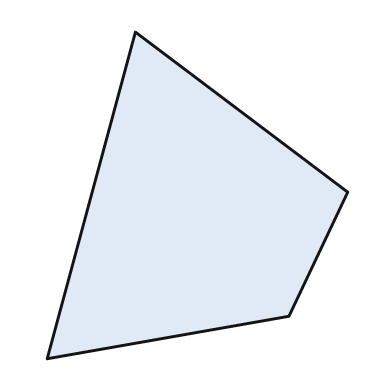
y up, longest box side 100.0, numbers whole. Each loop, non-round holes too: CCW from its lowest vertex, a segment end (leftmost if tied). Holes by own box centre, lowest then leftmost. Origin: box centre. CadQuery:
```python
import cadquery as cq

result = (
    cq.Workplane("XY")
    .moveTo(-46.0, -50.0)
    .lineTo(28.0, -37.0)
    .lineTo(46.0, 1.0)
    .lineTo(-19.0, 50.0)
    .close()
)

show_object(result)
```